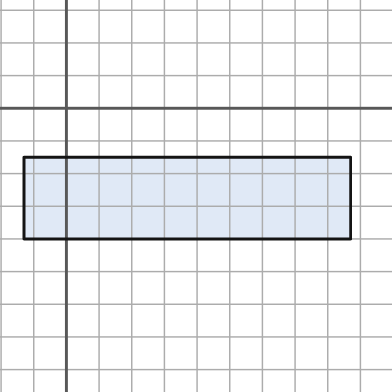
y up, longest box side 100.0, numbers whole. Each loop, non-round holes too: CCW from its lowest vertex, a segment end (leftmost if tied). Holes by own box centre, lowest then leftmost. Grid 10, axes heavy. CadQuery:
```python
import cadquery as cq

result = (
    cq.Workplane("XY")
    .moveTo(-13.0, -40.0)
    .lineTo(87.0, -40.0)
    .lineTo(87.0, -15.0)
    .lineTo(-13.0, -15.0)
    .close()
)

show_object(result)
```